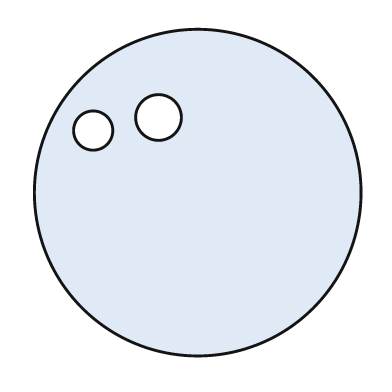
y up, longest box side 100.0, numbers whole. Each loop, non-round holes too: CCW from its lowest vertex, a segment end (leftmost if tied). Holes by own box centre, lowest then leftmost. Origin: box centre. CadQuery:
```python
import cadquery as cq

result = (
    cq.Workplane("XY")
    .moveTo(0.0, 0.0)
    .circle(50.0)
    .moveTo(-32.0, 19.0)
    .circle(6.0)
    .moveTo(-12.0, 23.0)
    .circle(7.0)
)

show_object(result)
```